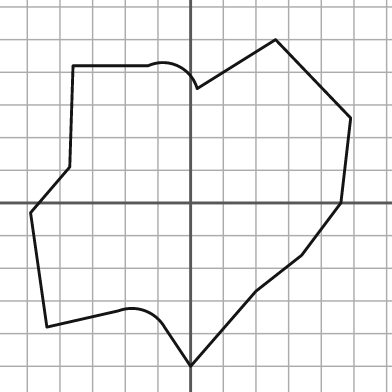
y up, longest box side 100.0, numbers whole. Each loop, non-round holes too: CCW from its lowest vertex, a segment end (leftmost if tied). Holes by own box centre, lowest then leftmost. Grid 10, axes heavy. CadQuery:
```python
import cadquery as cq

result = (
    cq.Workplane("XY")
    .moveTo(0.0, -50.0)
    .lineTo(20.0, -27.0)
    .lineTo(34.0, -16.0)
    .lineTo(46.0, 0.0)
    .lineTo(49.0, 26.0)
    .lineTo(26.0, 50.0)
    .lineTo(2.0, 35.0)
    .threePointArc((-4.0, 42.0), (-13.0, 42.0))
    .lineTo(-36.0, 42.0)
    .lineTo(-37.0, 11.0)
    .lineTo(-49.0, -3.0)
    .lineTo(-44.0, -38.0)
    .lineTo(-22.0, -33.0)
    .threePointArc((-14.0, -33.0), (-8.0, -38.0))
    .close()
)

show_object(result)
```